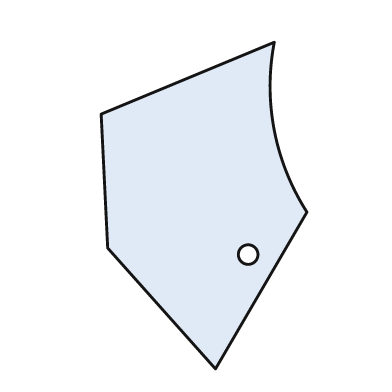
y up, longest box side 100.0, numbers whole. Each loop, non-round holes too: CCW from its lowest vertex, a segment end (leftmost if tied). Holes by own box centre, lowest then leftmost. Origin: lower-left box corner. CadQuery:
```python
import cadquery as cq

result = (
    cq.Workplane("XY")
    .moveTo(35.0, 0.0)
    .lineTo(63.0, 48.0)
    .threePointArc((53.0, 73.0), (53.0, 100.0))
    .lineTo(0.0, 78.0)
    .lineTo(2.0, 37.0)
    .close()
    .moveTo(45.0, 35.0)
    .circle(3.0)
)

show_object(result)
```